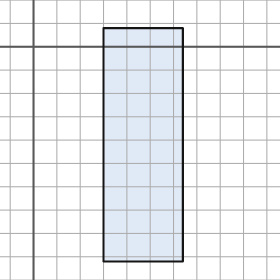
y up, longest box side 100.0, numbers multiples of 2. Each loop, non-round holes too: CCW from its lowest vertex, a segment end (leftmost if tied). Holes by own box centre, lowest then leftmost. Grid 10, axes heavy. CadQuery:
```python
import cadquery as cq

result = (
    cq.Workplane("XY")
    .moveTo(30.0, -92.0)
    .lineTo(64.0, -92.0)
    .lineTo(64.0, 8.0)
    .lineTo(30.0, 8.0)
    .close()
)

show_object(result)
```